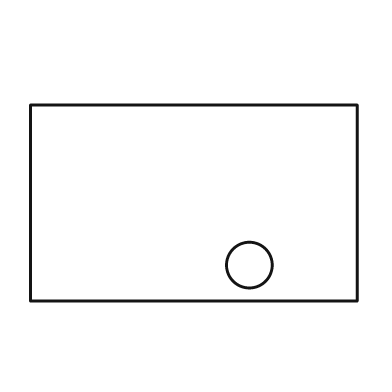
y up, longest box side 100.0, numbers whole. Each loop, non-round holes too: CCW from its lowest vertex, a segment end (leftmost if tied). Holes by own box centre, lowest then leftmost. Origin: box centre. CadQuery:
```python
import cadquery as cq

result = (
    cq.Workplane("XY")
    .moveTo(-50.0, -30.0)
    .lineTo(50.0, -30.0)
    .lineTo(50.0, 30.0)
    .lineTo(-50.0, 30.0)
    .close()
    .moveTo(17.0, -19.0)
    .circle(7.0)
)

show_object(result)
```